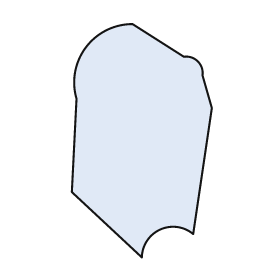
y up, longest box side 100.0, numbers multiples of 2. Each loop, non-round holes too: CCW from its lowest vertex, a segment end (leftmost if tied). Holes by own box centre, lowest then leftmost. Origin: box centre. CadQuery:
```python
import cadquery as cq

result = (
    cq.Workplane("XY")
    .moveTo(0.0, -50.0)
    .threePointArc((8.0, -38.0), (22.0, -40.0))
    .lineTo(30.0, 14.0)
    .lineTo(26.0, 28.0)
    .threePointArc((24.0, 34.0), (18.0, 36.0))
    .lineTo(-4.0, 50.0)
    .threePointArc((-24.0, 40.0), (-28.0, 18.0))
    .lineTo(-30.0, -22.0)
    .close()
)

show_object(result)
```